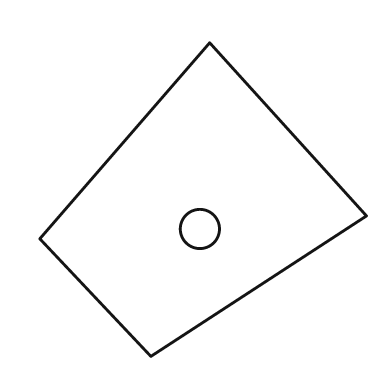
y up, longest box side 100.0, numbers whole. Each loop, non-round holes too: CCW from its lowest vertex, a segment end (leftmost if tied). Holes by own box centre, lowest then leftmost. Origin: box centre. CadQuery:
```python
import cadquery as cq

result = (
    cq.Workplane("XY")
    .moveTo(-16.0, -48.0)
    .lineTo(50.0, -5.0)
    .lineTo(2.0, 48.0)
    .lineTo(-50.0, -12.0)
    .close()
    .moveTo(-1.0, -9.0)
    .circle(6.0)
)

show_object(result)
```